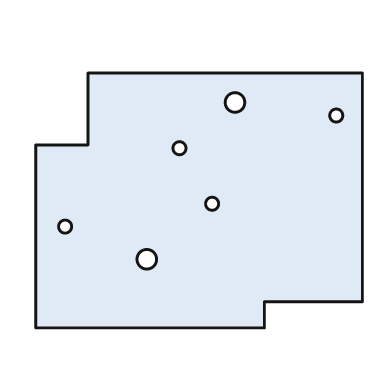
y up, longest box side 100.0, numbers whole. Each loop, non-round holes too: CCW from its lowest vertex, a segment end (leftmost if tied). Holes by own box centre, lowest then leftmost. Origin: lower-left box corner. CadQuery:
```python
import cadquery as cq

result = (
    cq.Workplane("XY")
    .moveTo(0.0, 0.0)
    .lineTo(70.0, 0.0)
    .lineTo(70.0, 8.0)
    .lineTo(100.0, 8.0)
    .lineTo(100.0, 78.0)
    .lineTo(16.0, 78.0)
    .lineTo(16.0, 56.0)
    .lineTo(0.0, 56.0)
    .close()
    .moveTo(34.0, 21.0)
    .circle(3.0)
    .moveTo(9.0, 31.0)
    .circle(2.0)
    .moveTo(54.0, 38.0)
    .circle(2.0)
    .moveTo(44.0, 55.0)
    .circle(2.0)
    .moveTo(92.0, 65.0)
    .circle(2.0)
    .moveTo(61.0, 69.0)
    .circle(3.0)
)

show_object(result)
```